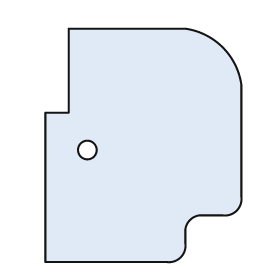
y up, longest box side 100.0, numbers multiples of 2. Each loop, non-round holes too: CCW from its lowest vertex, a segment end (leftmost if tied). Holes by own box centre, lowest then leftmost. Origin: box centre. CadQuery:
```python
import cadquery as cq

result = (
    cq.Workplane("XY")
    .moveTo(-42.0, -50.0)
    .lineTo(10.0, -50.0)
    .threePointArc((16.0, -48.0), (18.0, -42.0))
    .lineTo(18.0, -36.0)
    .threePointArc((20.0, -32.0), (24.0, -30.0))
    .lineTo(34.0, -30.0)
    .threePointArc((40.0, -28.0), (42.0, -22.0))
    .lineTo(42.0, 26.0)
    .threePointArc((34.0, 42.0), (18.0, 50.0))
    .lineTo(-32.0, 50.0)
    .lineTo(-32.0, 14.0)
    .lineTo(-42.0, 14.0)
    .close()
    .moveTo(-24.0, -2.0)
    .circle(4.0)
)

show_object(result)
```